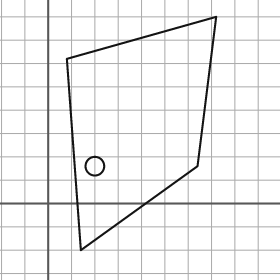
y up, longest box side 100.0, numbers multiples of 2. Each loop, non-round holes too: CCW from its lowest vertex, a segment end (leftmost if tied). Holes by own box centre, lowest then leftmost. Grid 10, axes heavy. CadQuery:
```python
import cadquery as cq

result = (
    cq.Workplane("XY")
    .moveTo(14.0, -20.0)
    .lineTo(64.0, 16.0)
    .lineTo(72.0, 80.0)
    .lineTo(8.0, 62.0)
    .close()
    .moveTo(20.0, 16.0)
    .circle(4.0)
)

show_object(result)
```